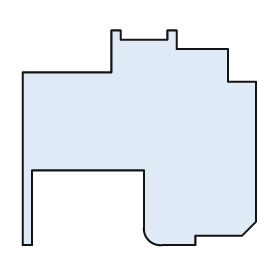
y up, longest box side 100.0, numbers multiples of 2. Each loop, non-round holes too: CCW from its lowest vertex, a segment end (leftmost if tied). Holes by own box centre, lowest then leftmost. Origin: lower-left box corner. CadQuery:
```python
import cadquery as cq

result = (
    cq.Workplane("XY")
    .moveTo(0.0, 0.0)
    .lineTo(4.0, 0.0)
    .lineTo(4.0, 32.0)
    .lineTo(52.0, 32.0)
    .lineTo(52.0, 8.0)
    .threePointArc((54.0, 2.0), (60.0, 0.0))
    .lineTo(74.0, 0.0)
    .lineTo(74.0, 4.0)
    .lineTo(94.0, 4.0)
    .lineTo(100.0, 10.0)
    .lineTo(100.0, 70.0)
    .lineTo(88.0, 70.0)
    .lineTo(88.0, 84.0)
    .lineTo(66.0, 84.0)
    .lineTo(66.0, 92.0)
    .lineTo(62.0, 92.0)
    .lineTo(62.0, 88.0)
    .lineTo(42.0, 88.0)
    .lineTo(42.0, 92.0)
    .lineTo(38.0, 92.0)
    .lineTo(38.0, 74.0)
    .lineTo(0.0, 74.0)
    .close()
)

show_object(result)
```